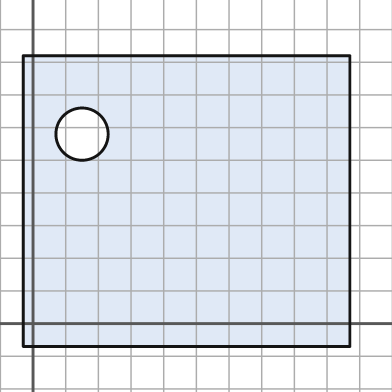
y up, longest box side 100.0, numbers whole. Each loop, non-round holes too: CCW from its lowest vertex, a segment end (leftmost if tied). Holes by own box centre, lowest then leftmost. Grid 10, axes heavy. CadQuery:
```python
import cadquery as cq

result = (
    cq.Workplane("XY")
    .moveTo(-3.0, -7.0)
    .lineTo(97.0, -7.0)
    .lineTo(97.0, 82.0)
    .lineTo(-3.0, 82.0)
    .close()
    .moveTo(15.0, 58.0)
    .circle(8.0)
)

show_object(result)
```